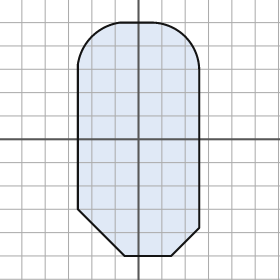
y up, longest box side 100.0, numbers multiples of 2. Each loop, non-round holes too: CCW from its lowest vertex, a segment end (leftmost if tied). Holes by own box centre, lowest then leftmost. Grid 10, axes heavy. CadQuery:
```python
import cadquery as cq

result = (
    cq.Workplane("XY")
    .moveTo(-6.0, -50.0)
    .lineTo(14.0, -50.0)
    .lineTo(26.0, -38.0)
    .lineTo(26.0, 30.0)
    .threePointArc((20.0, 44.0), (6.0, 50.0))
    .lineTo(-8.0, 50.0)
    .threePointArc((-20.0, 44.0), (-26.0, 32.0))
    .lineTo(-26.0, -30.0)
    .close()
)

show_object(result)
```